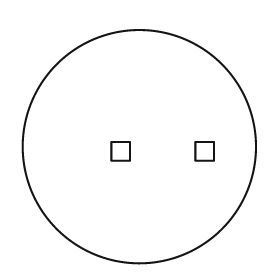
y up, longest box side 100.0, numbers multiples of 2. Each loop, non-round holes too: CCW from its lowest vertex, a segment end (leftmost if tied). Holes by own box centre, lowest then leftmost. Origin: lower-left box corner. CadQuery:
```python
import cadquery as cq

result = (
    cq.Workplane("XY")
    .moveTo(50.0, 50.0)
    .circle(50.0)
    .moveTo(38.0, 44.0)
    .lineTo(46.0, 44.0)
    .lineTo(46.0, 52.0)
    .lineTo(38.0, 52.0)
    .close()
    .moveTo(74.0, 44.0)
    .lineTo(82.0, 44.0)
    .lineTo(82.0, 52.0)
    .lineTo(74.0, 52.0)
    .close()
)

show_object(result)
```